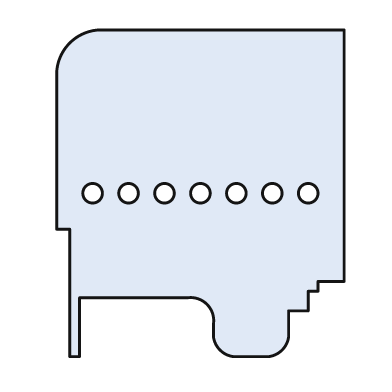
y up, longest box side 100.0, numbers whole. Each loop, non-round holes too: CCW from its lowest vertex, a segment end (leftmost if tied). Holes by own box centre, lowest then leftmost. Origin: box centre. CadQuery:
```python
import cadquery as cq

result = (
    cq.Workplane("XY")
    .moveTo(-40.0, -50.0)
    .lineTo(-37.0, -50.0)
    .lineTo(-37.0, -32.0)
    .lineTo(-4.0, -32.0)
    .threePointArc((2.0, -34.0), (4.0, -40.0))
    .lineTo(4.0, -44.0)
    .threePointArc((6.0, -48.0), (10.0, -50.0))
    .lineTo(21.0, -50.0)
    .threePointArc((25.0, -48.0), (27.0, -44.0))
    .lineTo(27.0, -36.0)
    .lineTo(33.0, -36.0)
    .lineTo(33.0, -30.0)
    .lineTo(36.0, -30.0)
    .lineTo(36.0, -27.0)
    .lineTo(44.0, -27.0)
    .lineTo(44.0, 50.0)
    .lineTo(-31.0, 50.0)
    .threePointArc((-40.0, 46.0), (-44.0, 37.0))
    .lineTo(-44.0, -11.0)
    .lineTo(-40.0, -11.0)
    .close()
    .moveTo(-33.0, 0.0)
    .circle(3.0)
    .moveTo(-22.0, 0.0)
    .circle(3.0)
    .moveTo(-11.0, 0.0)
    .circle(3.0)
    .moveTo(0.0, 0.0)
    .circle(3.0)
    .moveTo(11.0, 0.0)
    .circle(3.0)
    .moveTo(22.0, 0.0)
    .circle(3.0)
    .moveTo(33.0, 0.0)
    .circle(3.0)
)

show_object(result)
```